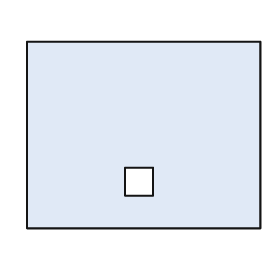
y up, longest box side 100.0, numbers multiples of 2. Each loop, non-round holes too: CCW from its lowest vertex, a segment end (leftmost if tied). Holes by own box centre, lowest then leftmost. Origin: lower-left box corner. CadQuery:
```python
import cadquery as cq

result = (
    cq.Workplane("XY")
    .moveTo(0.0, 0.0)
    .lineTo(100.0, 0.0)
    .lineTo(100.0, 80.0)
    .lineTo(0.0, 80.0)
    .close()
    .moveTo(42.0, 14.0)
    .lineTo(54.0, 14.0)
    .lineTo(54.0, 26.0)
    .lineTo(42.0, 26.0)
    .close()
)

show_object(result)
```